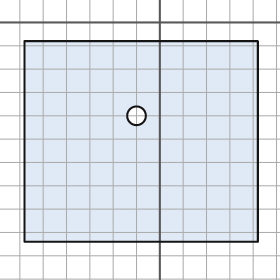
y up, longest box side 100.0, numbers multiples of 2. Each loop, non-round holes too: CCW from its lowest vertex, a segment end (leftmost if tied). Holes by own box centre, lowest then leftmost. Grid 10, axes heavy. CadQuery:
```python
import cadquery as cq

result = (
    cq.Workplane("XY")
    .moveTo(-58.0, -94.0)
    .lineTo(42.0, -94.0)
    .lineTo(42.0, -8.0)
    .lineTo(-58.0, -8.0)
    .close()
    .moveTo(-10.0, -40.0)
    .circle(4.0)
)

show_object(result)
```